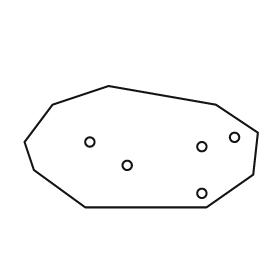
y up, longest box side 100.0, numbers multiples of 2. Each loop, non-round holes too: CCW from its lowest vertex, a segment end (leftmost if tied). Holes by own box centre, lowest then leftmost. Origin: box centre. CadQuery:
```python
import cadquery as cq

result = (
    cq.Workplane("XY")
    .moveTo(-24.0, -26.0)
    .lineTo(28.0, -26.0)
    .lineTo(48.0, -12.0)
    .lineTo(50.0, 6.0)
    .lineTo(32.0, 18.0)
    .lineTo(-14.0, 26.0)
    .lineTo(-38.0, 18.0)
    .lineTo(-50.0, 2.0)
    .lineTo(-46.0, -10.0)
    .close()
    .moveTo(26.0, -20.0)
    .circle(2.0)
    .moveTo(-6.0, -8.0)
    .circle(2.0)
    .moveTo(26.0, 0.0)
    .circle(2.0)
    .moveTo(-22.0, 2.0)
    .circle(2.0)
    .moveTo(40.0, 4.0)
    .circle(2.0)
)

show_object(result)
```